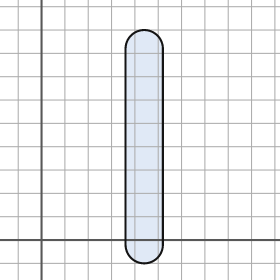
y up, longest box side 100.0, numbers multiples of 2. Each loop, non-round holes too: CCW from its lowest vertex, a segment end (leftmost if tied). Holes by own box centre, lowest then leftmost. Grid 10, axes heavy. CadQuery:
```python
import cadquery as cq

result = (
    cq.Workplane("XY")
    .moveTo(36.0, -2.0)
    .threePointArc((44.0, -10.0), (52.0, -2.0))
    .lineTo(52.0, 82.0)
    .threePointArc((44.0, 90.0), (36.0, 82.0))
    .close()
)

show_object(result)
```